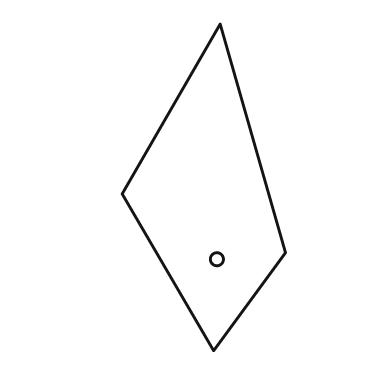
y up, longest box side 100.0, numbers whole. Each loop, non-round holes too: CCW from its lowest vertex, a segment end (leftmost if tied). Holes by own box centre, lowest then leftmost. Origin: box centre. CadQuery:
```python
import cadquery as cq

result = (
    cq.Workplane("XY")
    .moveTo(3.0, -50.0)
    .lineTo(25.0, -20.0)
    .lineTo(5.0, 50.0)
    .lineTo(-25.0, -2.0)
    .close()
    .moveTo(4.0, -22.0)
    .circle(2.0)
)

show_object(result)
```